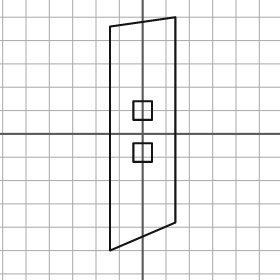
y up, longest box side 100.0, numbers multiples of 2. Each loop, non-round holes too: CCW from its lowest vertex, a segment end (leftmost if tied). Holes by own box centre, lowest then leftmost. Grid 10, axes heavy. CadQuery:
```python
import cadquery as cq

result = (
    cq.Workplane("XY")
    .moveTo(-14.0, -50.0)
    .lineTo(14.0, -38.0)
    .lineTo(14.0, 50.0)
    .lineTo(-14.0, 46.0)
    .close()
    .moveTo(-4.0, -12.0)
    .lineTo(4.0, -12.0)
    .lineTo(4.0, -4.0)
    .lineTo(-4.0, -4.0)
    .close()
    .moveTo(-4.0, 6.0)
    .lineTo(4.0, 6.0)
    .lineTo(4.0, 14.0)
    .lineTo(-4.0, 14.0)
    .close()
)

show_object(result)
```